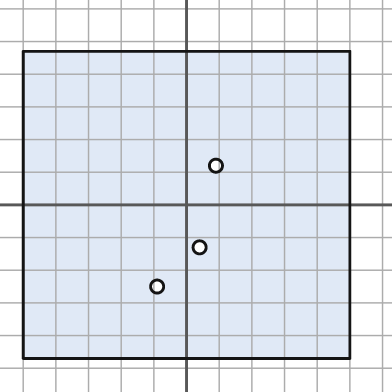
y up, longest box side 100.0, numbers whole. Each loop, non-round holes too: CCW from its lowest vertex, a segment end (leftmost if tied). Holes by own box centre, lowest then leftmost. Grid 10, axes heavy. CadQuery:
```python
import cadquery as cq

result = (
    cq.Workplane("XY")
    .moveTo(-50.0, -47.0)
    .lineTo(50.0, -47.0)
    .lineTo(50.0, 47.0)
    .lineTo(-50.0, 47.0)
    .close()
    .moveTo(-9.0, -25.0)
    .circle(2.0)
    .moveTo(4.0, -13.0)
    .circle(2.0)
    .moveTo(9.0, 12.0)
    .circle(2.0)
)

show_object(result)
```